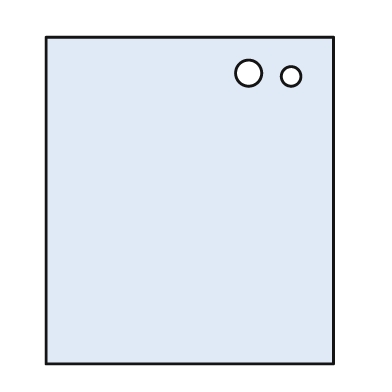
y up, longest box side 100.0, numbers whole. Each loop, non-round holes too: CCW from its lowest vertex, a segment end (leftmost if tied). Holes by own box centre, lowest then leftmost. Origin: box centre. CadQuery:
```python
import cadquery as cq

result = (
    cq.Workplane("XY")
    .moveTo(-44.0, -50.0)
    .lineTo(44.0, -50.0)
    .lineTo(44.0, 50.0)
    .lineTo(-44.0, 50.0)
    .close()
    .moveTo(31.0, 38.0)
    .circle(3.0)
    .moveTo(18.0, 39.0)
    .circle(4.0)
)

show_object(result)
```